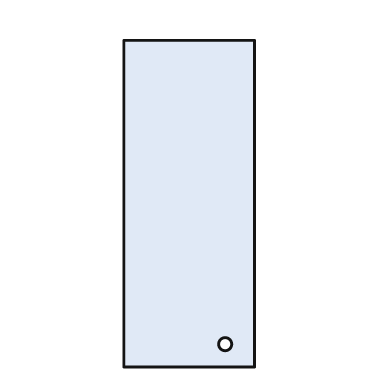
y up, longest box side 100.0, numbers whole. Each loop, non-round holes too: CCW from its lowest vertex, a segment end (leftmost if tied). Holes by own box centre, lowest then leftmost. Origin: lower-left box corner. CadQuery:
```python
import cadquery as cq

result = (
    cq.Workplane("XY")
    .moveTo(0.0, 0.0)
    .lineTo(40.0, 0.0)
    .lineTo(40.0, 100.0)
    .lineTo(0.0, 100.0)
    .close()
    .moveTo(31.0, 7.0)
    .circle(2.0)
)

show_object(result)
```